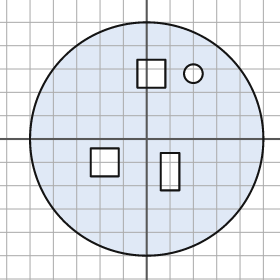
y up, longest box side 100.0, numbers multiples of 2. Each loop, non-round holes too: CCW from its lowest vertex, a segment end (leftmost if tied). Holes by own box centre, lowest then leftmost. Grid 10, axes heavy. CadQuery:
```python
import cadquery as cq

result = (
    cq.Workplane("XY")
    .moveTo(0.0, 0.0)
    .circle(50.0)
    .moveTo(6.0, -22.0)
    .lineTo(14.0, -22.0)
    .lineTo(14.0, -6.0)
    .lineTo(6.0, -6.0)
    .close()
    .moveTo(-24.0, -16.0)
    .lineTo(-12.0, -16.0)
    .lineTo(-12.0, -4.0)
    .lineTo(-24.0, -4.0)
    .close()
    .moveTo(-4.0, 22.0)
    .lineTo(8.0, 22.0)
    .lineTo(8.0, 34.0)
    .lineTo(-4.0, 34.0)
    .close()
    .moveTo(20.0, 28.0)
    .circle(4.0)
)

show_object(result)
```